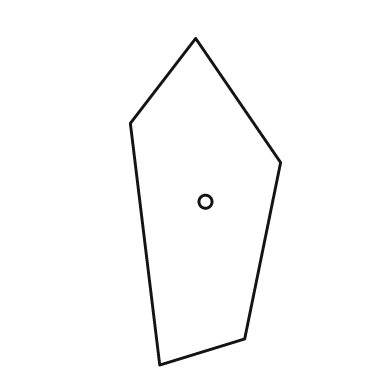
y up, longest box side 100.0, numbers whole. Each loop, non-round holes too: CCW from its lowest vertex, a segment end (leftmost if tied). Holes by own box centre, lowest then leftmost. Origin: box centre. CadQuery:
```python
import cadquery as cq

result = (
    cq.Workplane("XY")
    .moveTo(-14.0, -50.0)
    .lineTo(12.0, -42.0)
    .lineTo(23.0, 12.0)
    .lineTo(-3.0, 50.0)
    .lineTo(-23.0, 24.0)
    .close()
    .moveTo(0.0, 0.0)
    .circle(2.0)
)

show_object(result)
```